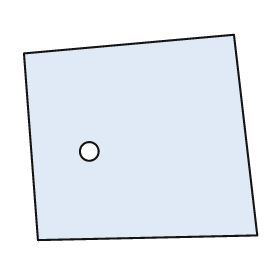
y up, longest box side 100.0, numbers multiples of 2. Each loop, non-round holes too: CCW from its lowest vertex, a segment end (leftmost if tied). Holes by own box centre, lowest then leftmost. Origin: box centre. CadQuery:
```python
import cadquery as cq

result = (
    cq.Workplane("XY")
    .moveTo(-44.0, -44.0)
    .lineTo(50.0, -42.0)
    .lineTo(40.0, 44.0)
    .lineTo(-50.0, 36.0)
    .close()
    .moveTo(-22.0, -6.0)
    .circle(4.0)
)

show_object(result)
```